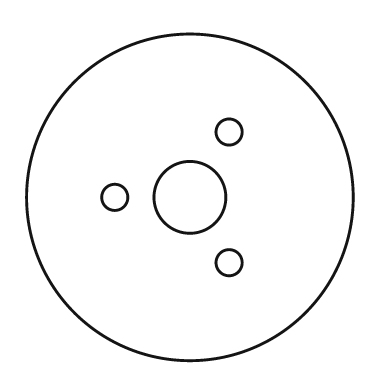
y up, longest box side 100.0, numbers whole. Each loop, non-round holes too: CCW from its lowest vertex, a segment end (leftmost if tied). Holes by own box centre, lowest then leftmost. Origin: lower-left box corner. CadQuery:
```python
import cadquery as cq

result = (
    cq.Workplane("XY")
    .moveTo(50.0, 50.0)
    .circle(50.0)
    .moveTo(62.0, 30.0)
    .circle(4.0)
    .moveTo(27.0, 50.0)
    .circle(4.0)
    .moveTo(50.0, 50.0)
    .circle(11.0)
    .moveTo(62.0, 70.0)
    .circle(4.0)
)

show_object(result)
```